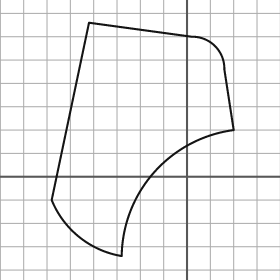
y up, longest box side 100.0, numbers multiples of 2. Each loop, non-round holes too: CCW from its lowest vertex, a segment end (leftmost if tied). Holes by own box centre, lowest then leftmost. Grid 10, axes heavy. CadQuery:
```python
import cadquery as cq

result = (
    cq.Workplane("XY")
    .moveTo(-28.0, -34.0)
    .threePointArc((-14.0, 2.0), (20.0, 20.0))
    .lineTo(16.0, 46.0)
    .threePointArc((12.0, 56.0), (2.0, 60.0))
    .lineTo(-42.0, 66.0)
    .lineTo(-58.0, -10.0)
    .threePointArc((-46.0, -26.0), (-28.0, -34.0))
    .close()
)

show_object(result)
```